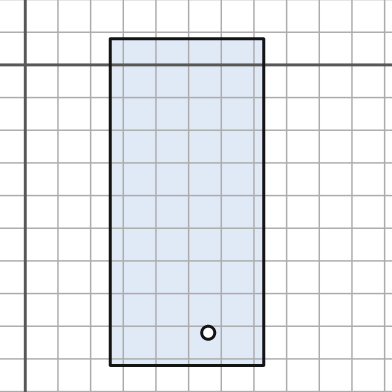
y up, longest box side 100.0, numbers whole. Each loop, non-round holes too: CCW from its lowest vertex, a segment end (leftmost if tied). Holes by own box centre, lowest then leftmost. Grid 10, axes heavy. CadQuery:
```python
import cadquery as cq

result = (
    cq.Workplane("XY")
    .moveTo(26.0, -92.0)
    .lineTo(73.0, -92.0)
    .lineTo(73.0, 8.0)
    .lineTo(26.0, 8.0)
    .close()
    .moveTo(56.0, -82.0)
    .circle(2.0)
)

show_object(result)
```